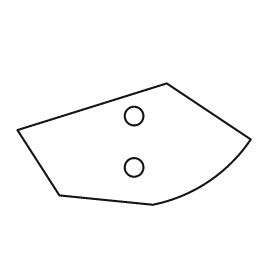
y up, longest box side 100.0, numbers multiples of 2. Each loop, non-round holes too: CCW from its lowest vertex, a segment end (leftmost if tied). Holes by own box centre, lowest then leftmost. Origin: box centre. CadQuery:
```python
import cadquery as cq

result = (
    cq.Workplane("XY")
    .moveTo(8.0, -26.0)
    .threePointArc((32.0, -16.0), (50.0, 2.0))
    .lineTo(14.0, 26.0)
    .lineTo(-50.0, 6.0)
    .lineTo(-32.0, -22.0)
    .close()
    .moveTo(0.0, -10.0)
    .circle(4.0)
    .moveTo(0.0, 12.0)
    .circle(4.0)
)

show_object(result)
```